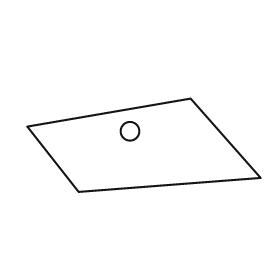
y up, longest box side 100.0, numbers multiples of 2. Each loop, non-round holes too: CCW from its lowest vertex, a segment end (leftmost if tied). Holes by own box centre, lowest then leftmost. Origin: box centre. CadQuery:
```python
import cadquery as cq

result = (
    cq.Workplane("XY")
    .moveTo(-28.0, -20.0)
    .lineTo(50.0, -14.0)
    .lineTo(20.0, 20.0)
    .lineTo(-50.0, 8.0)
    .close()
    .moveTo(-6.0, 6.0)
    .circle(4.0)
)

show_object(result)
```